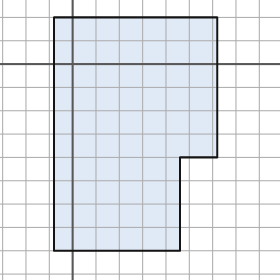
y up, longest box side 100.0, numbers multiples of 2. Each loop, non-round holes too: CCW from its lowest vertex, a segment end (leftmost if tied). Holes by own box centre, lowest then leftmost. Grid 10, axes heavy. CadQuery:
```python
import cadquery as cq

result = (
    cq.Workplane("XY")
    .moveTo(-8.0, -80.0)
    .lineTo(46.0, -80.0)
    .lineTo(46.0, -40.0)
    .lineTo(62.0, -40.0)
    .lineTo(62.0, 20.0)
    .lineTo(-8.0, 20.0)
    .close()
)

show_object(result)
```